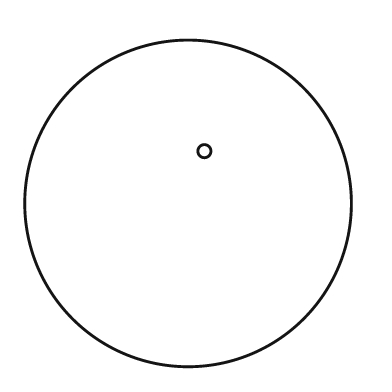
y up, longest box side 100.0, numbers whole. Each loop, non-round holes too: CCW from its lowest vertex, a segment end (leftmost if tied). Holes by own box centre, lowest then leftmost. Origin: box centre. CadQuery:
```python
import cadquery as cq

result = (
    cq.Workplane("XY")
    .moveTo(0.0, 0.0)
    .circle(50.0)
    .moveTo(5.0, 16.0)
    .circle(2.0)
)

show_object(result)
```